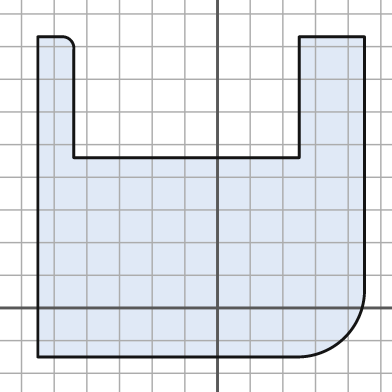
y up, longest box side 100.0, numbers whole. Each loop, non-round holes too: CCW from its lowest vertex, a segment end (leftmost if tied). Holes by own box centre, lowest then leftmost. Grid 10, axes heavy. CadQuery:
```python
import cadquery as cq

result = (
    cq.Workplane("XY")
    .moveTo(-55.0, -15.0)
    .lineTo(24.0, -15.0)
    .threePointArc((39.0, -9.0), (45.0, 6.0))
    .lineTo(45.0, 83.0)
    .lineTo(25.0, 83.0)
    .lineTo(25.0, 46.0)
    .lineTo(-44.0, 46.0)
    .lineTo(-44.0, 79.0)
    .threePointArc((-45.0, 82.0), (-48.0, 83.0))
    .lineTo(-55.0, 83.0)
    .close()
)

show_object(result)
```